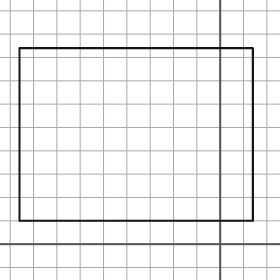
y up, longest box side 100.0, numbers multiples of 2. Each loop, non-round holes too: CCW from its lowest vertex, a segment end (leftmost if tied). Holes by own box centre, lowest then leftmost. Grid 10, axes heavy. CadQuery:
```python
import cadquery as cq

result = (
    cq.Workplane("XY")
    .moveTo(-86.0, 10.0)
    .lineTo(14.0, 10.0)
    .lineTo(14.0, 84.0)
    .lineTo(-86.0, 84.0)
    .close()
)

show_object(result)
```